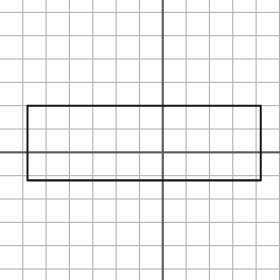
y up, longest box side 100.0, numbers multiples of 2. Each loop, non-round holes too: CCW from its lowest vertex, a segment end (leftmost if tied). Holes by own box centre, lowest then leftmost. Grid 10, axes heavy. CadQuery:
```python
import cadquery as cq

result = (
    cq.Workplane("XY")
    .moveTo(-58.0, -12.0)
    .lineTo(42.0, -12.0)
    .lineTo(42.0, 20.0)
    .lineTo(-58.0, 20.0)
    .close()
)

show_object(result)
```